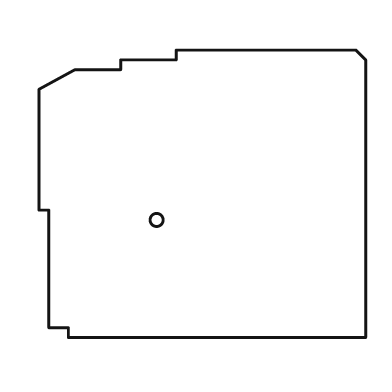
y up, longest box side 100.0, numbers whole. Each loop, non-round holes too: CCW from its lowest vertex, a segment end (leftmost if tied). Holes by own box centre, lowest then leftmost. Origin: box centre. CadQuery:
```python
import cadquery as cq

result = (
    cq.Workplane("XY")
    .moveTo(-41.0, -44.0)
    .lineTo(50.0, -44.0)
    .lineTo(50.0, 41.0)
    .lineTo(47.0, 44.0)
    .lineTo(-8.0, 44.0)
    .lineTo(-8.0, 41.0)
    .lineTo(-25.0, 41.0)
    .lineTo(-25.0, 38.0)
    .lineTo(-39.0, 38.0)
    .lineTo(-50.0, 32.0)
    .lineTo(-50.0, -5.0)
    .lineTo(-47.0, -5.0)
    .lineTo(-47.0, -41.0)
    .lineTo(-41.0, -41.0)
    .close()
    .moveTo(-14.0, -8.0)
    .circle(2.0)
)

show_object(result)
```